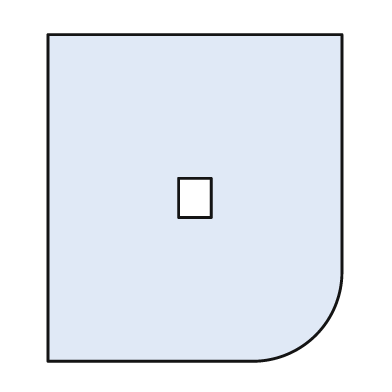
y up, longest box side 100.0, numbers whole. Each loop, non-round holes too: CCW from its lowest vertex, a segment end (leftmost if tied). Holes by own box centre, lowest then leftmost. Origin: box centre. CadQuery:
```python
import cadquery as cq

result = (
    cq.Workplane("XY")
    .moveTo(-45.0, -50.0)
    .lineTo(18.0, -50.0)
    .threePointArc((37.0, -42.0), (45.0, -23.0))
    .lineTo(45.0, 50.0)
    .lineTo(-45.0, 50.0)
    .close()
    .moveTo(-5.0, -6.0)
    .lineTo(5.0, -6.0)
    .lineTo(5.0, 6.0)
    .lineTo(-5.0, 6.0)
    .close()
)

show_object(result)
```